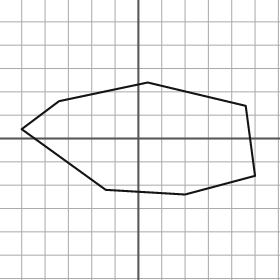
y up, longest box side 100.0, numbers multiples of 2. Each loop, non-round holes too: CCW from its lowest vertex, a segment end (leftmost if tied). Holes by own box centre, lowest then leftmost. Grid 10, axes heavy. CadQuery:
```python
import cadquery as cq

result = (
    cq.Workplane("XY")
    .moveTo(20.0, -24.0)
    .lineTo(50.0, -16.0)
    .lineTo(46.0, 14.0)
    .lineTo(4.0, 24.0)
    .lineTo(-34.0, 16.0)
    .lineTo(-50.0, 4.0)
    .lineTo(-14.0, -22.0)
    .close()
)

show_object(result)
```